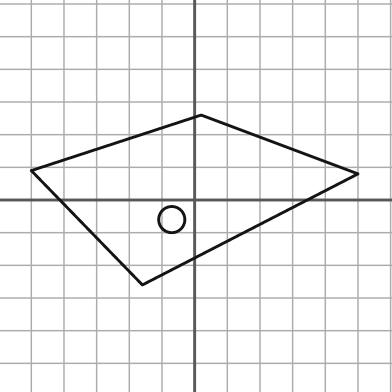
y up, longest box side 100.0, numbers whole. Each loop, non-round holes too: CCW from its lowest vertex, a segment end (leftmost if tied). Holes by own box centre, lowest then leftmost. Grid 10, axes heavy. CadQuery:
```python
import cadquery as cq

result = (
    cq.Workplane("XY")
    .moveTo(-16.0, -26.0)
    .lineTo(50.0, 8.0)
    .lineTo(2.0, 26.0)
    .lineTo(-50.0, 9.0)
    .close()
    .moveTo(-7.0, -6.0)
    .circle(4.0)
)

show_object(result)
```